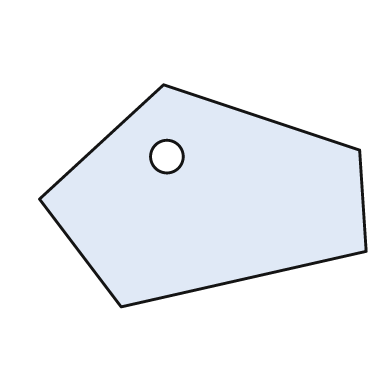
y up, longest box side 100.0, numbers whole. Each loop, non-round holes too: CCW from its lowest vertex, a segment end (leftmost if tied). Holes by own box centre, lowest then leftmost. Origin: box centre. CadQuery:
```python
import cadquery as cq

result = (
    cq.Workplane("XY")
    .moveTo(-25.0, -34.0)
    .lineTo(50.0, -17.0)
    .lineTo(48.0, 14.0)
    .lineTo(-12.0, 34.0)
    .lineTo(-50.0, -1.0)
    .close()
    .moveTo(-11.0, 12.0)
    .circle(5.0)
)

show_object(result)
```